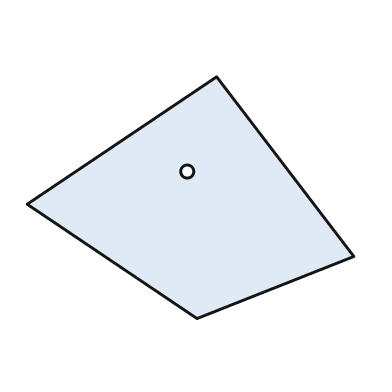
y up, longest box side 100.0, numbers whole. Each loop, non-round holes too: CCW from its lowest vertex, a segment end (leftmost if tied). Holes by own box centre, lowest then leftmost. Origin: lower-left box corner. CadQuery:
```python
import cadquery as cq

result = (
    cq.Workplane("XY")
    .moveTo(52.0, 0.0)
    .lineTo(100.0, 19.0)
    .lineTo(58.0, 74.0)
    .lineTo(0.0, 35.0)
    .close()
    .moveTo(49.0, 45.0)
    .circle(2.0)
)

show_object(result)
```